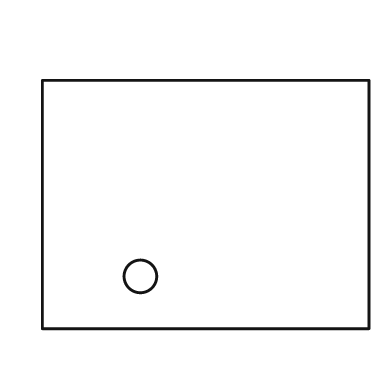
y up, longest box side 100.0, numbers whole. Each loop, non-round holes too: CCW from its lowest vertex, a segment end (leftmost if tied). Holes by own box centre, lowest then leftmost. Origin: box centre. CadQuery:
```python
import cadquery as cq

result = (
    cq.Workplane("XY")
    .moveTo(-50.0, -38.0)
    .lineTo(50.0, -38.0)
    .lineTo(50.0, 38.0)
    .lineTo(-50.0, 38.0)
    .close()
    .moveTo(-20.0, -22.0)
    .circle(5.0)
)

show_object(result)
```